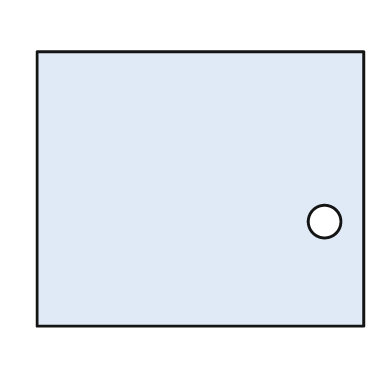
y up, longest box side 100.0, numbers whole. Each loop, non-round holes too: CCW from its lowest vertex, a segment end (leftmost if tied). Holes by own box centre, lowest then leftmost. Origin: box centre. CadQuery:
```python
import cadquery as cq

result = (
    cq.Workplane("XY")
    .moveTo(-50.0, -42.0)
    .lineTo(50.0, -42.0)
    .lineTo(50.0, 42.0)
    .lineTo(-50.0, 42.0)
    .close()
    .moveTo(38.0, -10.0)
    .circle(5.0)
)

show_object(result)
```